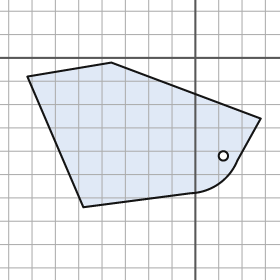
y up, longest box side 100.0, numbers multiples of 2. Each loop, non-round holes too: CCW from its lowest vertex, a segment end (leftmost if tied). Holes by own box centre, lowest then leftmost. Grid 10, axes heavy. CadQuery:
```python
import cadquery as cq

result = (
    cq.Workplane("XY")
    .moveTo(-48.0, -64.0)
    .lineTo(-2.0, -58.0)
    .threePointArc((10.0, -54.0), (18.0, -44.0))
    .lineTo(28.0, -26.0)
    .lineTo(-36.0, -2.0)
    .lineTo(-72.0, -8.0)
    .close()
    .moveTo(12.0, -42.0)
    .circle(2.0)
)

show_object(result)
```